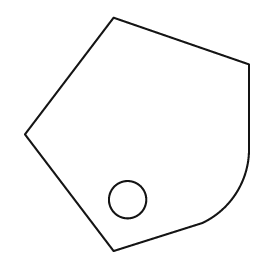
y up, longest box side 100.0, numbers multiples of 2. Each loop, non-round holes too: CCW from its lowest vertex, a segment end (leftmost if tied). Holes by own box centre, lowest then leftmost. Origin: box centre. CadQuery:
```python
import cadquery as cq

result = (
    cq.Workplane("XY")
    .moveTo(-10.0, -50.0)
    .lineTo(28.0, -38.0)
    .threePointArc((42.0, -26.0), (48.0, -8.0))
    .lineTo(48.0, 30.0)
    .lineTo(-10.0, 50.0)
    .lineTo(-48.0, 0.0)
    .close()
    .moveTo(-4.0, -28.0)
    .circle(8.0)
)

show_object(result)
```